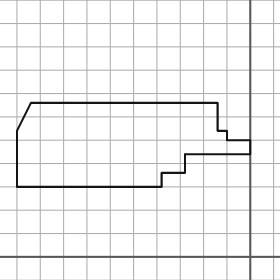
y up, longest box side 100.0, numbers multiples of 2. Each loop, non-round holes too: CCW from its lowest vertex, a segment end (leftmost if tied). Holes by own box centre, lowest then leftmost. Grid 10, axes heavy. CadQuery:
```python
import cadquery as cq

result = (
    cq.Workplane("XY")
    .moveTo(-100.0, 30.0)
    .lineTo(-38.0, 30.0)
    .lineTo(-38.0, 36.0)
    .lineTo(-28.0, 36.0)
    .lineTo(-28.0, 44.0)
    .lineTo(0.0, 44.0)
    .lineTo(0.0, 50.0)
    .lineTo(-10.0, 50.0)
    .lineTo(-10.0, 54.0)
    .lineTo(-14.0, 54.0)
    .lineTo(-14.0, 66.0)
    .lineTo(-94.0, 66.0)
    .lineTo(-100.0, 54.0)
    .close()
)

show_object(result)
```